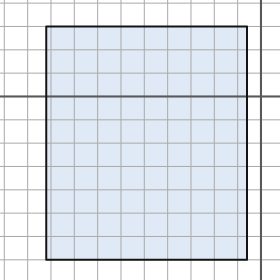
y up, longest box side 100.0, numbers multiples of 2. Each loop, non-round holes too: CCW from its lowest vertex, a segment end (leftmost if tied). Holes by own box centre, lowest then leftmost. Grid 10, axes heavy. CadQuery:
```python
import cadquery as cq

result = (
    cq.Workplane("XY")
    .moveTo(-92.0, -70.0)
    .lineTo(-6.0, -70.0)
    .lineTo(-6.0, 30.0)
    .lineTo(-92.0, 30.0)
    .close()
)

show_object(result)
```